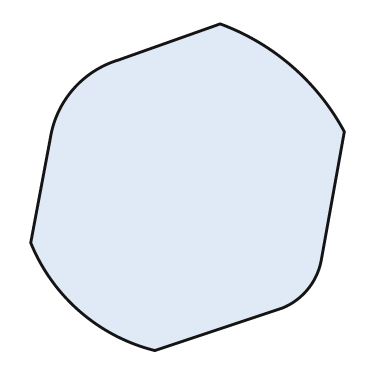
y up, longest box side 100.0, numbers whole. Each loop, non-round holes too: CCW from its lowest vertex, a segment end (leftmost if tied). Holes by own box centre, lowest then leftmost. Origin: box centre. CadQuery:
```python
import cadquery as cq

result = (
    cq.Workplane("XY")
    .moveTo(-10.0, -50.0)
    .lineTo(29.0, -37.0)
    .threePointArc((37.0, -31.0), (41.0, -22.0))
    .lineTo(48.0, 17.0)
    .threePointArc((32.0, 37.0), (10.0, 50.0))
    .lineTo(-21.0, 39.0)
    .threePointArc((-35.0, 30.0), (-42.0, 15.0))
    .lineTo(-48.0, -17.0)
    .threePointArc((-33.0, -38.0), (-10.0, -50.0))
    .close()
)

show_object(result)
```